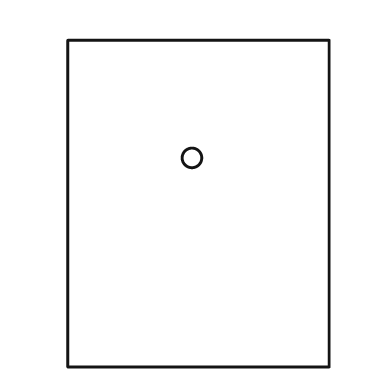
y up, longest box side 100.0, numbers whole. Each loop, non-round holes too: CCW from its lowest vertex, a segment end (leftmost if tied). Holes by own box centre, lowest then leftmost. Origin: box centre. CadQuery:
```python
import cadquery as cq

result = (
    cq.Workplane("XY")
    .moveTo(-40.0, -50.0)
    .lineTo(40.0, -50.0)
    .lineTo(40.0, 50.0)
    .lineTo(-40.0, 50.0)
    .close()
    .moveTo(-2.0, 14.0)
    .circle(3.0)
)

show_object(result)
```